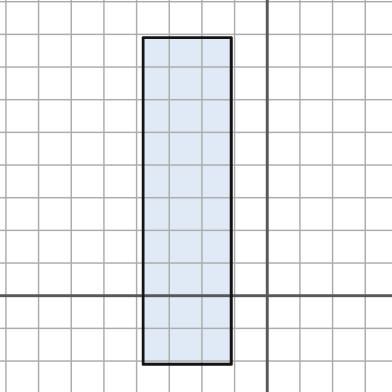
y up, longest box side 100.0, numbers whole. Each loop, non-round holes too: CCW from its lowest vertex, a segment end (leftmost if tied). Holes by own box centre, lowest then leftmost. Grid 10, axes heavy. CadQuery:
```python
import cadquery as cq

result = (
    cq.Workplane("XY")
    .moveTo(-38.0, -21.0)
    .lineTo(-11.0, -21.0)
    .lineTo(-11.0, 79.0)
    .lineTo(-38.0, 79.0)
    .close()
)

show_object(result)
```